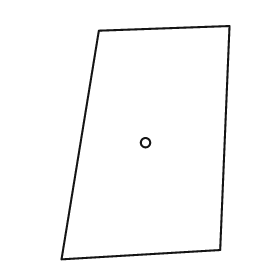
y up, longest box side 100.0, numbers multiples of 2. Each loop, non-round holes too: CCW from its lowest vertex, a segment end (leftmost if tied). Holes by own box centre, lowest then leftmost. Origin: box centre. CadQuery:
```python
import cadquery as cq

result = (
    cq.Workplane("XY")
    .moveTo(-36.0, -50.0)
    .lineTo(32.0, -46.0)
    .lineTo(36.0, 50.0)
    .lineTo(-20.0, 48.0)
    .close()
    .moveTo(0.0, 0.0)
    .circle(2.0)
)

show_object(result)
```